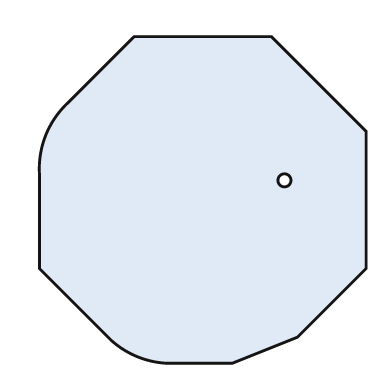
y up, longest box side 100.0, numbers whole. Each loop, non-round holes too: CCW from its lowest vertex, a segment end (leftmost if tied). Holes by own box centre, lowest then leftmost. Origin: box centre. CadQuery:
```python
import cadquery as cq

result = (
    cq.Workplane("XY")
    .moveTo(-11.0, -50.0)
    .lineTo(9.0, -50.0)
    .lineTo(29.0, -42.0)
    .lineTo(50.0, -21.0)
    .lineTo(50.0, 21.0)
    .lineTo(21.0, 50.0)
    .lineTo(-21.0, 50.0)
    .lineTo(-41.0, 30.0)
    .threePointArc((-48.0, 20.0), (-50.0, 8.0))
    .lineTo(-50.0, -21.0)
    .lineTo(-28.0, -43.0)
    .threePointArc((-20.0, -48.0), (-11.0, -50.0))
    .close()
    .moveTo(25.0, 6.0)
    .circle(2.0)
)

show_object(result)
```